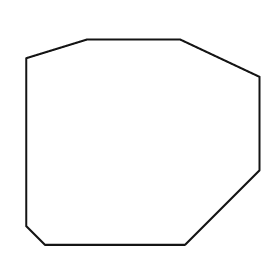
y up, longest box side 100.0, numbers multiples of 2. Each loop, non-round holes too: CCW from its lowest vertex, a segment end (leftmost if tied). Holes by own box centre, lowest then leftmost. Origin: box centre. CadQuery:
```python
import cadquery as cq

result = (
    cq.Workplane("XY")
    .moveTo(-42.0, -44.0)
    .lineTo(18.0, -44.0)
    .lineTo(50.0, -12.0)
    .lineTo(50.0, 28.0)
    .lineTo(16.0, 44.0)
    .lineTo(-24.0, 44.0)
    .lineTo(-50.0, 36.0)
    .lineTo(-50.0, -36.0)
    .close()
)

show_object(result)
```